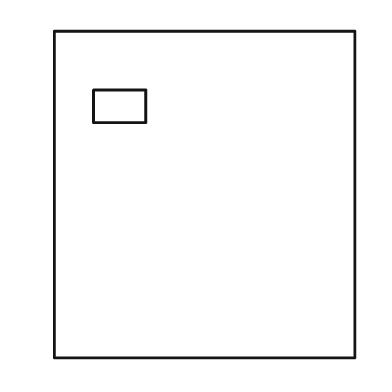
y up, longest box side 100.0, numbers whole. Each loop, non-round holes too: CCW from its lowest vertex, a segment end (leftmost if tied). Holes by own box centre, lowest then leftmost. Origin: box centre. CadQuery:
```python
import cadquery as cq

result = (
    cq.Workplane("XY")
    .moveTo(-46.0, -50.0)
    .lineTo(46.0, -50.0)
    .lineTo(46.0, 50.0)
    .lineTo(-46.0, 50.0)
    .close()
    .moveTo(-34.0, 22.0)
    .lineTo(-18.0, 22.0)
    .lineTo(-18.0, 32.0)
    .lineTo(-34.0, 32.0)
    .close()
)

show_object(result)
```